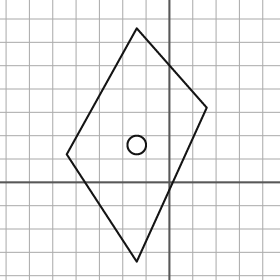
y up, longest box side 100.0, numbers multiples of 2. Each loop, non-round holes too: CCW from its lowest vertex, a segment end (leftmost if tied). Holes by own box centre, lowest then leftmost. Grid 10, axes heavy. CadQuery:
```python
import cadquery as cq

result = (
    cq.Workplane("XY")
    .moveTo(-14.0, -34.0)
    .lineTo(16.0, 32.0)
    .lineTo(-14.0, 66.0)
    .lineTo(-44.0, 12.0)
    .close()
    .moveTo(-14.0, 16.0)
    .circle(4.0)
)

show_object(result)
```